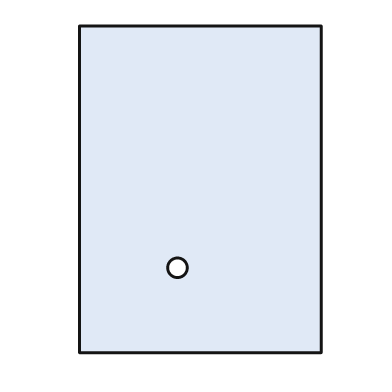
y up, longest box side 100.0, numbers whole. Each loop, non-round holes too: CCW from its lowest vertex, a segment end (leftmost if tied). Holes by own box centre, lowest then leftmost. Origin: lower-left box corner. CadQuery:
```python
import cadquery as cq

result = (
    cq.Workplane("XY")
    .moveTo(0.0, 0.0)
    .lineTo(74.0, 0.0)
    .lineTo(74.0, 100.0)
    .lineTo(0.0, 100.0)
    .close()
    .moveTo(30.0, 26.0)
    .circle(3.0)
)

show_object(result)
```